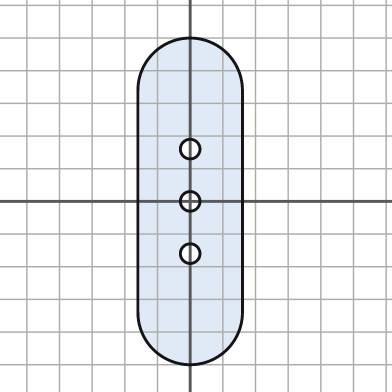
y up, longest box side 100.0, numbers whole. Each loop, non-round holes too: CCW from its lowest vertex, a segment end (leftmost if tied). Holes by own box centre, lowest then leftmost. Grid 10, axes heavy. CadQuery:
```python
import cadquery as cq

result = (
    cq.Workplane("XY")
    .moveTo(-16.0, -34.0)
    .threePointArc((0.0, -50.0), (16.0, -34.0))
    .lineTo(16.0, 34.0)
    .threePointArc((0.0, 50.0), (-16.0, 34.0))
    .close()
    .moveTo(0.0, -16.0)
    .circle(3.0)
    .moveTo(0.0, 0.0)
    .circle(3.0)
    .moveTo(0.0, 16.0)
    .circle(3.0)
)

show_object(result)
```